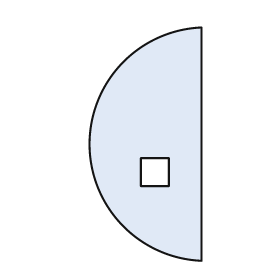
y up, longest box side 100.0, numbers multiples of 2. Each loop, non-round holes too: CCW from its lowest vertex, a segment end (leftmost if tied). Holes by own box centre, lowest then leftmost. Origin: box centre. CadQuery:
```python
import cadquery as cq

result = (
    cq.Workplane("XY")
    .moveTo(24.0, -50.0)
    .lineTo(24.0, 50.0)
    .threePointArc((-24.0, 0.0), (24.0, -50.0))
    .close()
    .moveTo(-2.0, -18.0)
    .lineTo(10.0, -18.0)
    .lineTo(10.0, -6.0)
    .lineTo(-2.0, -6.0)
    .close()
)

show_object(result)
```